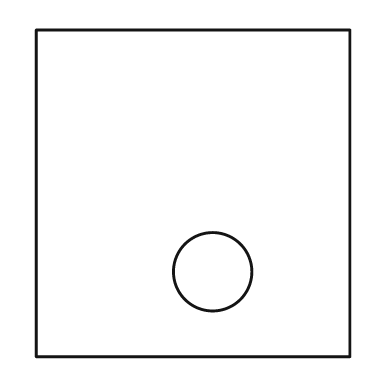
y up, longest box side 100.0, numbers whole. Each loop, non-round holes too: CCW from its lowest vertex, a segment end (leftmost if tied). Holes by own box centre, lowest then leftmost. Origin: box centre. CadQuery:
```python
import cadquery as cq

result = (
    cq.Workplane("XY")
    .moveTo(-48.0, -50.0)
    .lineTo(48.0, -50.0)
    .lineTo(48.0, 50.0)
    .lineTo(-48.0, 50.0)
    .close()
    .moveTo(6.0, -24.0)
    .circle(12.0)
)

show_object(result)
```